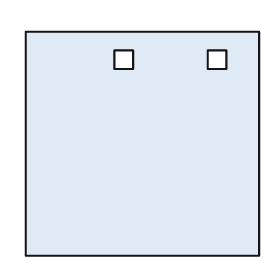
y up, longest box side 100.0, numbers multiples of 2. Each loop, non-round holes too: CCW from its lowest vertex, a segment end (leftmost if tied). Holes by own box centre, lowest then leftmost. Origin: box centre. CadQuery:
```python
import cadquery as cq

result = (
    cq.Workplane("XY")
    .moveTo(-50.0, -48.0)
    .lineTo(50.0, -48.0)
    .lineTo(50.0, 48.0)
    .lineTo(-50.0, 48.0)
    .close()
    .moveTo(-12.0, 32.0)
    .lineTo(-4.0, 32.0)
    .lineTo(-4.0, 40.0)
    .lineTo(-12.0, 40.0)
    .close()
    .moveTo(28.0, 32.0)
    .lineTo(36.0, 32.0)
    .lineTo(36.0, 40.0)
    .lineTo(28.0, 40.0)
    .close()
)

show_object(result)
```